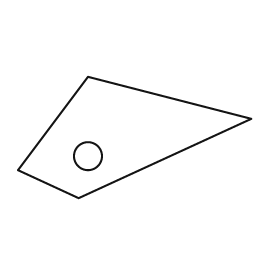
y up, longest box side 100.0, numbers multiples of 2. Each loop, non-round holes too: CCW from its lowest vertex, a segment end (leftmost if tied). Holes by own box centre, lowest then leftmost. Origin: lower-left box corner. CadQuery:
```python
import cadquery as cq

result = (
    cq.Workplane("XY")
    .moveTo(26.0, 0.0)
    .lineTo(100.0, 34.0)
    .lineTo(30.0, 52.0)
    .lineTo(0.0, 12.0)
    .close()
    .moveTo(30.0, 18.0)
    .circle(6.0)
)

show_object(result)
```